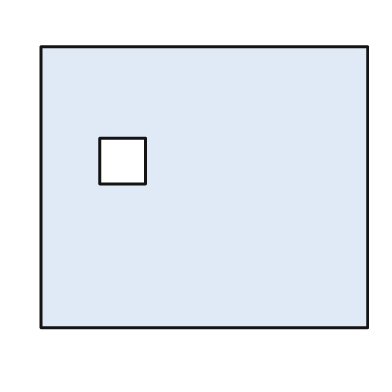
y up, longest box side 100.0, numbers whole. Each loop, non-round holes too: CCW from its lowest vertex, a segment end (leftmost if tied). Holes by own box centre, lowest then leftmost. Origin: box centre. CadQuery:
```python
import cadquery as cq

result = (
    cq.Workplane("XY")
    .moveTo(-50.0, -43.0)
    .lineTo(50.0, -43.0)
    .lineTo(50.0, 43.0)
    .lineTo(-50.0, 43.0)
    .close()
    .moveTo(-32.0, 1.0)
    .lineTo(-18.0, 1.0)
    .lineTo(-18.0, 15.0)
    .lineTo(-32.0, 15.0)
    .close()
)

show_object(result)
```